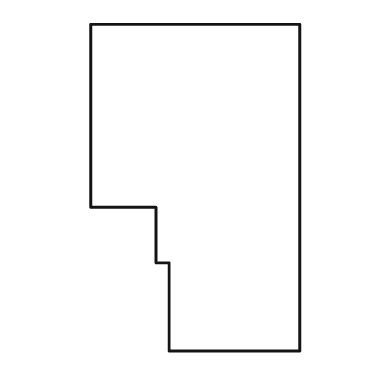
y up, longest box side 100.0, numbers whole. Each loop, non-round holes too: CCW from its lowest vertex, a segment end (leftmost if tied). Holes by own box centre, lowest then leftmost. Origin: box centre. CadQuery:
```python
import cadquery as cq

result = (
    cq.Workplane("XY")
    .moveTo(-8.0, -50.0)
    .lineTo(32.0, -50.0)
    .lineTo(32.0, 50.0)
    .lineTo(-32.0, 50.0)
    .lineTo(-32.0, -6.0)
    .lineTo(-12.0, -6.0)
    .lineTo(-12.0, -23.0)
    .lineTo(-8.0, -23.0)
    .close()
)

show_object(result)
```